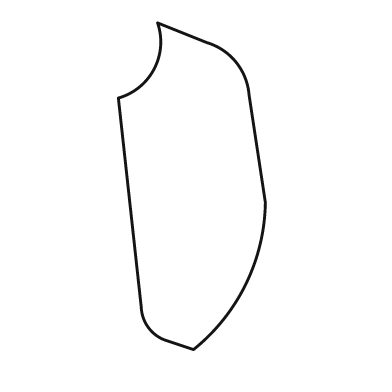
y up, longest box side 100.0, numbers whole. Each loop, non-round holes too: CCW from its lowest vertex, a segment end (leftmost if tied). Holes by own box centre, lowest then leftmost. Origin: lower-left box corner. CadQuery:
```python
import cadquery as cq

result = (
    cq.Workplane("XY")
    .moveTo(23.0, 0.0)
    .threePointArc((39.0, 20.0), (45.0, 45.0))
    .lineTo(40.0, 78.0)
    .threePointArc((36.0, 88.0), (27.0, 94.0))
    .lineTo(12.0, 100.0)
    .threePointArc((11.0, 86.0), (0.0, 77.0))
    .lineTo(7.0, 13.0)
    .threePointArc((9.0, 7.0), (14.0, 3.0))
    .close()
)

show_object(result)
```